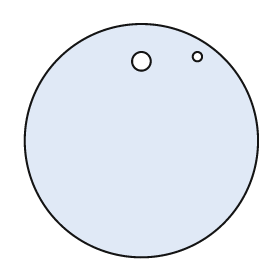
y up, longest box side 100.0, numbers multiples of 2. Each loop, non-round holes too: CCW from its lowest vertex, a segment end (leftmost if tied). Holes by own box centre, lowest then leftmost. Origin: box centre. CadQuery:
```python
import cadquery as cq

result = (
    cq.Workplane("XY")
    .moveTo(0.0, 0.0)
    .circle(50.0)
    .moveTo(0.0, 34.0)
    .circle(4.0)
    .moveTo(24.0, 36.0)
    .circle(2.0)
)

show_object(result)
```